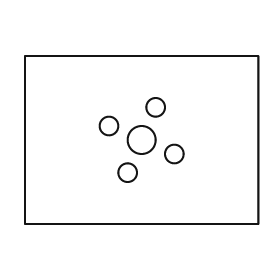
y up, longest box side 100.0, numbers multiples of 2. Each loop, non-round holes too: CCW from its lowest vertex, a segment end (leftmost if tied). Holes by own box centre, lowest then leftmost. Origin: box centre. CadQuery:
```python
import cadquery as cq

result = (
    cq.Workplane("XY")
    .moveTo(-50.0, -36.0)
    .lineTo(50.0, -36.0)
    .lineTo(50.0, 36.0)
    .lineTo(-50.0, 36.0)
    .close()
    .moveTo(-6.0, -14.0)
    .circle(4.0)
    .moveTo(14.0, -6.0)
    .circle(4.0)
    .moveTo(0.0, 0.0)
    .circle(6.0)
    .moveTo(-14.0, 6.0)
    .circle(4.0)
    .moveTo(6.0, 14.0)
    .circle(4.0)
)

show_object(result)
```